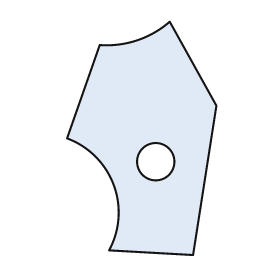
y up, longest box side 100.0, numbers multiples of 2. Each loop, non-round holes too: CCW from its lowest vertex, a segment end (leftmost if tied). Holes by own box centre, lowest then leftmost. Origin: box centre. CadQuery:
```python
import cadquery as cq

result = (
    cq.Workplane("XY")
    .moveTo(22.0, -50.0)
    .lineTo(32.0, 14.0)
    .lineTo(12.0, 50.0)
    .threePointArc((-2.0, 42.0), (-18.0, 40.0))
    .lineTo(-32.0, 0.0)
    .threePointArc((-12.0, -20.0), (-14.0, -48.0))
    .close()
    .moveTo(6.0, -10.0)
    .circle(8.0)
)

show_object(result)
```